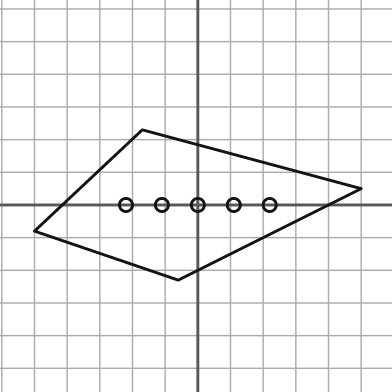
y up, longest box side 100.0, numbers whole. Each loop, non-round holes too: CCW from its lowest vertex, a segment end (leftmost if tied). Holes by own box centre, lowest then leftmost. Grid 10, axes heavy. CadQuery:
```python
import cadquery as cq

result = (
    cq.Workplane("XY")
    .moveTo(-6.0, -23.0)
    .lineTo(50.0, 5.0)
    .lineTo(-17.0, 23.0)
    .lineTo(-50.0, -8.0)
    .close()
    .moveTo(-22.0, 0.0)
    .circle(2.0)
    .moveTo(-11.0, 0.0)
    .circle(2.0)
    .moveTo(0.0, 0.0)
    .circle(2.0)
    .moveTo(11.0, 0.0)
    .circle(2.0)
    .moveTo(22.0, 0.0)
    .circle(2.0)
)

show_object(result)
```